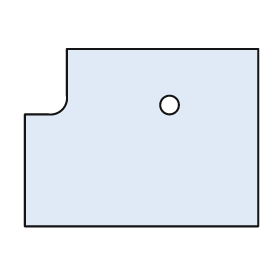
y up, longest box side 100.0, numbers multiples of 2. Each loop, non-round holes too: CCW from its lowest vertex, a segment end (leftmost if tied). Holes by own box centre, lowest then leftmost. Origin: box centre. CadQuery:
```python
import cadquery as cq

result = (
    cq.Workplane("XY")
    .moveTo(-50.0, -38.0)
    .lineTo(50.0, -38.0)
    .lineTo(50.0, 38.0)
    .lineTo(-32.0, 38.0)
    .lineTo(-32.0, 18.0)
    .threePointArc((-34.0, 12.0), (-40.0, 10.0))
    .lineTo(-50.0, 10.0)
    .close()
    .moveTo(12.0, 14.0)
    .circle(4.0)
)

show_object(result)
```